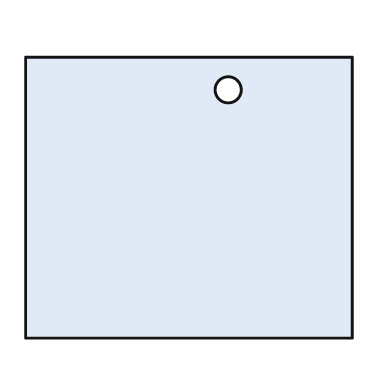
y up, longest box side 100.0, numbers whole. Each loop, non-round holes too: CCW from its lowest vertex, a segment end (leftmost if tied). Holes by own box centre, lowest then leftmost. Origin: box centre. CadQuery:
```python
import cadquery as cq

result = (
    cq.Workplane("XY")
    .moveTo(-50.0, -43.0)
    .lineTo(50.0, -43.0)
    .lineTo(50.0, 43.0)
    .lineTo(-50.0, 43.0)
    .close()
    .moveTo(12.0, 33.0)
    .circle(4.0)
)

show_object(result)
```